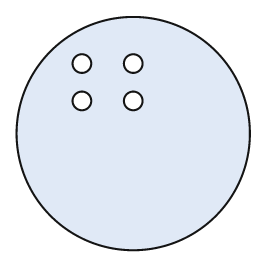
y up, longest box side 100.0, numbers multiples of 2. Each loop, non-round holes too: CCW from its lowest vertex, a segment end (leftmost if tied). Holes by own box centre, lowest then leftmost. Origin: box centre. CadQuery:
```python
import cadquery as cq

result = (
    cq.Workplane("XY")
    .moveTo(0.0, 0.0)
    .circle(50.0)
    .moveTo(-22.0, 14.0)
    .circle(4.0)
    .moveTo(0.0, 14.0)
    .circle(4.0)
    .moveTo(-22.0, 30.0)
    .circle(4.0)
    .moveTo(0.0, 30.0)
    .circle(4.0)
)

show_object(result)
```